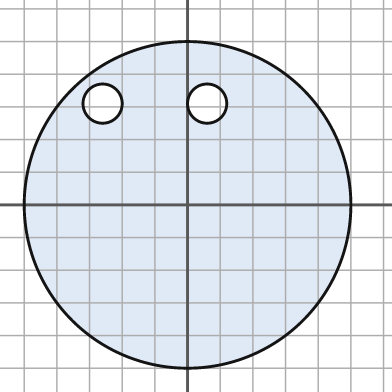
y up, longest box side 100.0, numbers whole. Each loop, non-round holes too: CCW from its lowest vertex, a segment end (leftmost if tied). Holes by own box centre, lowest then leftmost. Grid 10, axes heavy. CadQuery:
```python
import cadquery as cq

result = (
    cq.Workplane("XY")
    .moveTo(0.0, 0.0)
    .circle(50.0)
    .moveTo(-26.0, 31.0)
    .circle(6.0)
    .moveTo(6.0, 31.0)
    .circle(6.0)
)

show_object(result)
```